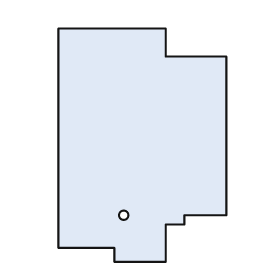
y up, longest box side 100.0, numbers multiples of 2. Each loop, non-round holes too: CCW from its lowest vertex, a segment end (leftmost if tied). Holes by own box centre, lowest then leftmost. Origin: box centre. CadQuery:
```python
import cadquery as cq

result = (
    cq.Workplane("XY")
    .moveTo(-12.0, -50.0)
    .lineTo(10.0, -50.0)
    .lineTo(10.0, -34.0)
    .lineTo(18.0, -34.0)
    .lineTo(18.0, -30.0)
    .lineTo(36.0, -30.0)
    .lineTo(36.0, 38.0)
    .lineTo(10.0, 38.0)
    .lineTo(10.0, 50.0)
    .lineTo(-36.0, 50.0)
    .lineTo(-36.0, -44.0)
    .lineTo(-12.0, -44.0)
    .close()
    .moveTo(-8.0, -30.0)
    .circle(2.0)
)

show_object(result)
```